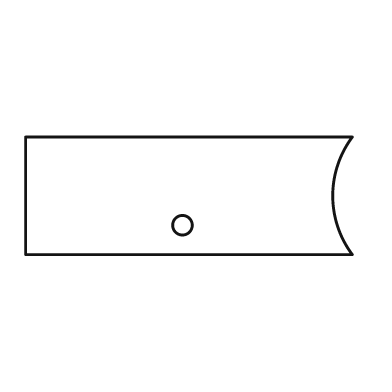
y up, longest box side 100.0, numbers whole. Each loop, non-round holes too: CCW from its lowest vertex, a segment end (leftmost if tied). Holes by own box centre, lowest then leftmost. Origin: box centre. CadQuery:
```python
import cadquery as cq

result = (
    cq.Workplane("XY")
    .moveTo(-50.0, -18.0)
    .lineTo(50.0, -18.0)
    .threePointArc((44.0, 0.0), (50.0, 18.0))
    .lineTo(-50.0, 18.0)
    .close()
    .moveTo(-2.0, -9.0)
    .circle(3.0)
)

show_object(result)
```